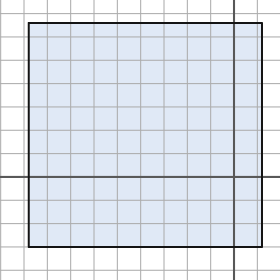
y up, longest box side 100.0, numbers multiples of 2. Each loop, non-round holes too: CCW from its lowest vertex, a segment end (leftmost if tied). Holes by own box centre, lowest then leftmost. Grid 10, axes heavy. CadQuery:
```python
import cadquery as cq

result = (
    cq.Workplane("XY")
    .moveTo(-88.0, -30.0)
    .lineTo(12.0, -30.0)
    .lineTo(12.0, 66.0)
    .lineTo(-88.0, 66.0)
    .close()
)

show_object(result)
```